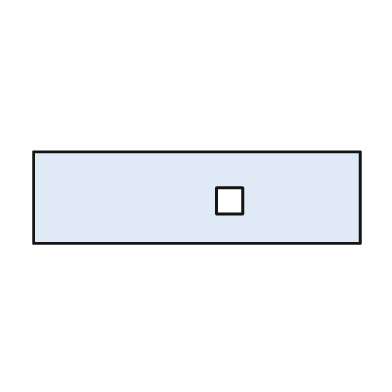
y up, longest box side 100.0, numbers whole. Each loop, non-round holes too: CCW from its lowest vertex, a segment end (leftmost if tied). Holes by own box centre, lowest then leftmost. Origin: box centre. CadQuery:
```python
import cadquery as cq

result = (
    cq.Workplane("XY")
    .moveTo(-50.0, -14.0)
    .lineTo(50.0, -14.0)
    .lineTo(50.0, 14.0)
    .lineTo(-50.0, 14.0)
    .close()
    .moveTo(6.0, -5.0)
    .lineTo(14.0, -5.0)
    .lineTo(14.0, 3.0)
    .lineTo(6.0, 3.0)
    .close()
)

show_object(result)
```